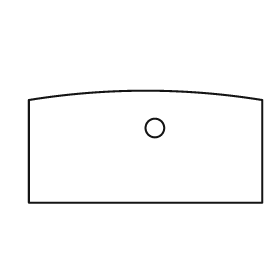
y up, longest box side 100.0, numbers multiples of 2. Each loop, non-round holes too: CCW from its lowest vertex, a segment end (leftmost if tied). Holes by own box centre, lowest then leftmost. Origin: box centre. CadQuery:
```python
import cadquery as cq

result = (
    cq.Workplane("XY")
    .moveTo(-50.0, -24.0)
    .lineTo(50.0, -24.0)
    .lineTo(50.0, 20.0)
    .threePointArc((0.0, 24.0), (-50.0, 20.0))
    .close()
    .moveTo(4.0, 8.0)
    .circle(4.0)
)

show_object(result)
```